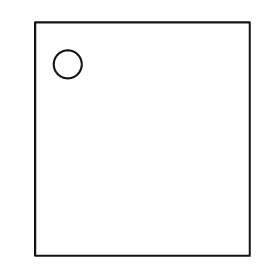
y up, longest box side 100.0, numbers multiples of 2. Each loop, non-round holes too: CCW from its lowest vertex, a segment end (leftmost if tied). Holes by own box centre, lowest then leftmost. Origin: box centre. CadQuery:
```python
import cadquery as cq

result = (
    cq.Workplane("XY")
    .moveTo(-46.0, -50.0)
    .lineTo(46.0, -50.0)
    .lineTo(46.0, 50.0)
    .lineTo(-46.0, 50.0)
    .close()
    .moveTo(-32.0, 32.0)
    .circle(6.0)
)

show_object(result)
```